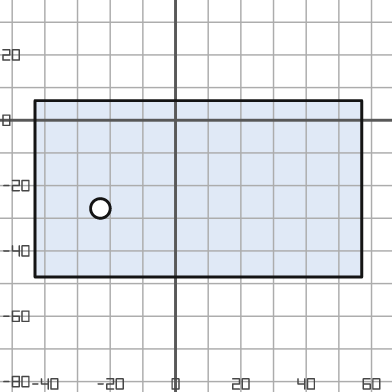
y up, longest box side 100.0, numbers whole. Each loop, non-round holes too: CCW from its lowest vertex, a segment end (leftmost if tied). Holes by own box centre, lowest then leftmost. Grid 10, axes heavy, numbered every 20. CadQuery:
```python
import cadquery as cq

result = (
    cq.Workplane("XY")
    .moveTo(-43.0, -48.0)
    .lineTo(57.0, -48.0)
    .lineTo(57.0, 6.0)
    .lineTo(-43.0, 6.0)
    .close()
    .moveTo(-23.0, -27.0)
    .circle(3.0)
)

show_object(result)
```